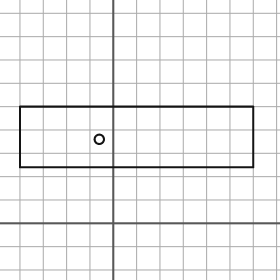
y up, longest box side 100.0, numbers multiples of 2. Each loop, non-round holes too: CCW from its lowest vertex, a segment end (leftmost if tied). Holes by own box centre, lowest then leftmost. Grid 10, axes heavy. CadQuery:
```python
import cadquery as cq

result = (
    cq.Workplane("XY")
    .moveTo(-40.0, 24.0)
    .lineTo(60.0, 24.0)
    .lineTo(60.0, 50.0)
    .lineTo(-40.0, 50.0)
    .close()
    .moveTo(-6.0, 36.0)
    .circle(2.0)
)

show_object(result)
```